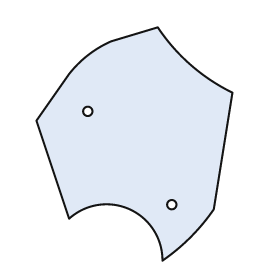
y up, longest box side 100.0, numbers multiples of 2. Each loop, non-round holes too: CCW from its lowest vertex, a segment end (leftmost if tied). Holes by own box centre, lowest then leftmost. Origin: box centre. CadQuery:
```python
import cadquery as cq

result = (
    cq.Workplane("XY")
    .moveTo(12.0, -50.0)
    .threePointArc((24.0, -40.0), (34.0, -28.0))
    .lineTo(42.0, 22.0)
    .threePointArc((24.0, 34.0), (10.0, 50.0))
    .lineTo(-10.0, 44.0)
    .threePointArc((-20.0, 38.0), (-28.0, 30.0))
    .lineTo(-42.0, 10.0)
    .lineTo(-28.0, -32.0)
    .threePointArc((-2.0, -28.0), (12.0, -50.0))
    .close()
    .moveTo(16.0, -26.0)
    .circle(2.0)
    .moveTo(-20.0, 14.0)
    .circle(2.0)
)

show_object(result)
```